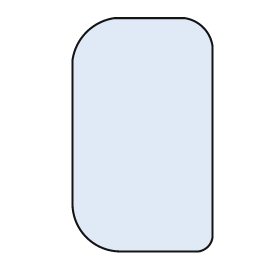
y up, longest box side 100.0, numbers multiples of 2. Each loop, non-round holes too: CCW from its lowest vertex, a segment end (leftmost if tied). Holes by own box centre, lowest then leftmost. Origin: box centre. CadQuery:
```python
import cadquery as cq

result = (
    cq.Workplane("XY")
    .moveTo(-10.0, -50.0)
    .lineTo(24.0, -50.0)
    .threePointArc((28.0, -48.0), (30.0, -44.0))
    .lineTo(30.0, 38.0)
    .threePointArc((26.0, 46.0), (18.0, 50.0))
    .lineTo(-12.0, 50.0)
    .threePointArc((-24.0, 44.0), (-30.0, 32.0))
    .lineTo(-30.0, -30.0)
    .threePointArc((-24.0, -44.0), (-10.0, -50.0))
    .close()
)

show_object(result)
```